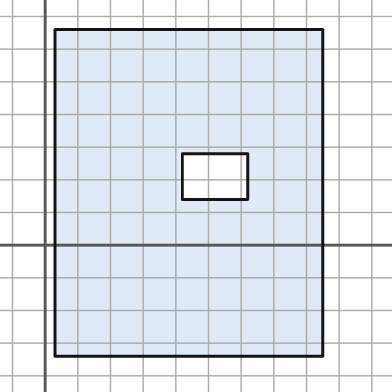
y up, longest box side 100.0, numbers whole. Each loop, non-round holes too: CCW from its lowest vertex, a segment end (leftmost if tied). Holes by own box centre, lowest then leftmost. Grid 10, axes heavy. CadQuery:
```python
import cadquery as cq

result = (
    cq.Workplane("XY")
    .moveTo(3.0, -34.0)
    .lineTo(85.0, -34.0)
    .lineTo(85.0, 66.0)
    .lineTo(3.0, 66.0)
    .close()
    .moveTo(42.0, 14.0)
    .lineTo(62.0, 14.0)
    .lineTo(62.0, 28.0)
    .lineTo(42.0, 28.0)
    .close()
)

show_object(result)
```